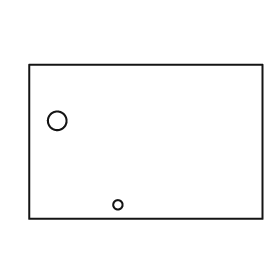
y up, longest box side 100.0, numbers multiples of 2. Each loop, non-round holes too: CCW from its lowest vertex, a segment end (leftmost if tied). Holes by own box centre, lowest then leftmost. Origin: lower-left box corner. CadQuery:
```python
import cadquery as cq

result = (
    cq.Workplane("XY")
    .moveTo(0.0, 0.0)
    .lineTo(100.0, 0.0)
    .lineTo(100.0, 66.0)
    .lineTo(0.0, 66.0)
    .close()
    .moveTo(38.0, 6.0)
    .circle(2.0)
    .moveTo(12.0, 42.0)
    .circle(4.0)
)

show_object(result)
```